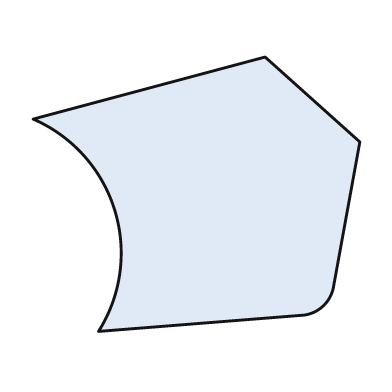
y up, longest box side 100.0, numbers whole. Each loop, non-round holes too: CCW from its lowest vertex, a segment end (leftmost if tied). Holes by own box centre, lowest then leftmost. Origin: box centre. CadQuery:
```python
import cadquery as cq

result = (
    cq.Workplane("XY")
    .moveTo(-30.0, -42.0)
    .lineTo(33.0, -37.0)
    .threePointArc((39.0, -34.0), (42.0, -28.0))
    .lineTo(50.0, 16.0)
    .lineTo(21.0, 42.0)
    .lineTo(-50.0, 23.0)
    .threePointArc((-25.0, -5.0), (-30.0, -42.0))
    .close()
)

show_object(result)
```